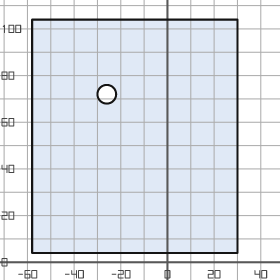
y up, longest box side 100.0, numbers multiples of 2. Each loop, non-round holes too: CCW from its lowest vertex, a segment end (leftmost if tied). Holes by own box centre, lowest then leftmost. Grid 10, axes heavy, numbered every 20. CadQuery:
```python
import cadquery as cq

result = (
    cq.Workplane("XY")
    .moveTo(-58.0, 4.0)
    .lineTo(30.0, 4.0)
    .lineTo(30.0, 104.0)
    .lineTo(-58.0, 104.0)
    .close()
    .moveTo(-26.0, 72.0)
    .circle(4.0)
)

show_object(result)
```